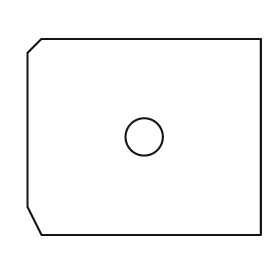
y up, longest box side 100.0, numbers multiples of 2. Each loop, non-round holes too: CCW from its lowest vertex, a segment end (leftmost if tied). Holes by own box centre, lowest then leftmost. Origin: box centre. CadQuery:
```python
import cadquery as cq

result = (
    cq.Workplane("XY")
    .moveTo(-44.0, -42.0)
    .lineTo(50.0, -42.0)
    .lineTo(50.0, 42.0)
    .lineTo(-44.0, 42.0)
    .lineTo(-50.0, 36.0)
    .lineTo(-50.0, -30.0)
    .close()
    .moveTo(0.0, 0.0)
    .circle(8.0)
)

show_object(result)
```